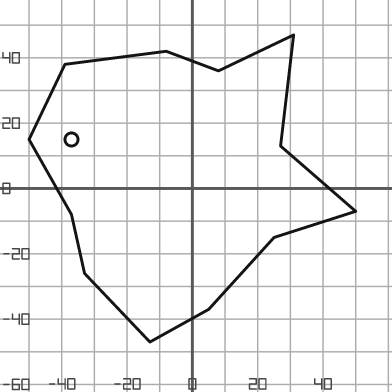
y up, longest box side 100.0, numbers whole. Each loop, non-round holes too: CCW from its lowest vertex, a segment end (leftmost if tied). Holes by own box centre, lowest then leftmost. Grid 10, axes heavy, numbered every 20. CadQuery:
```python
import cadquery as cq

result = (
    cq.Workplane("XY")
    .moveTo(-13.0, -47.0)
    .lineTo(5.0, -37.0)
    .lineTo(25.0, -15.0)
    .lineTo(50.0, -7.0)
    .lineTo(27.0, 13.0)
    .lineTo(31.0, 47.0)
    .lineTo(8.0, 36.0)
    .lineTo(-8.0, 42.0)
    .lineTo(-39.0, 38.0)
    .lineTo(-50.0, 15.0)
    .lineTo(-37.0, -8.0)
    .lineTo(-33.0, -26.0)
    .close()
    .moveTo(-37.0, 15.0)
    .circle(2.0)
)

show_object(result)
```